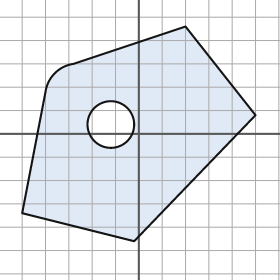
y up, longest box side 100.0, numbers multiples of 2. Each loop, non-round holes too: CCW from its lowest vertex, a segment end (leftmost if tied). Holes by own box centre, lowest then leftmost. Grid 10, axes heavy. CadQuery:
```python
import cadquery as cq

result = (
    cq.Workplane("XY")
    .moveTo(-2.0, -46.0)
    .lineTo(50.0, 8.0)
    .lineTo(20.0, 46.0)
    .lineTo(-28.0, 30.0)
    .threePointArc((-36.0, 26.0), (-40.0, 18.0))
    .lineTo(-50.0, -34.0)
    .close()
    .moveTo(-12.0, 4.0)
    .circle(10.0)
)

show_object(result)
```